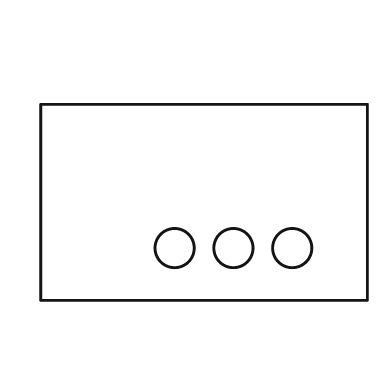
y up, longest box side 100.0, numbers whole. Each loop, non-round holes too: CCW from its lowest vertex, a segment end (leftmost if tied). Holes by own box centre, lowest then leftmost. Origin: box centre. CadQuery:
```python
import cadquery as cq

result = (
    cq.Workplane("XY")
    .moveTo(-50.0, -30.0)
    .lineTo(50.0, -30.0)
    .lineTo(50.0, 30.0)
    .lineTo(-50.0, 30.0)
    .close()
    .moveTo(-9.0, -14.0)
    .circle(6.0)
    .moveTo(9.0, -14.0)
    .circle(6.0)
    .moveTo(27.0, -14.0)
    .circle(6.0)
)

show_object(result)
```